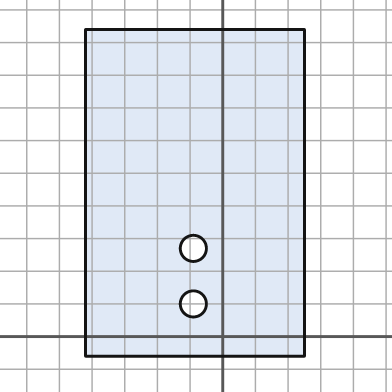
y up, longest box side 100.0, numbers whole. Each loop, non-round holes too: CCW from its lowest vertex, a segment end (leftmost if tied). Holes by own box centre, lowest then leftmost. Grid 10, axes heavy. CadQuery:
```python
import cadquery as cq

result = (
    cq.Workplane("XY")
    .moveTo(-42.0, -6.0)
    .lineTo(25.0, -6.0)
    .lineTo(25.0, 94.0)
    .lineTo(-42.0, 94.0)
    .close()
    .moveTo(-9.0, 10.0)
    .circle(4.0)
    .moveTo(-9.0, 27.0)
    .circle(4.0)
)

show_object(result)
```